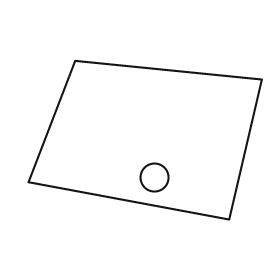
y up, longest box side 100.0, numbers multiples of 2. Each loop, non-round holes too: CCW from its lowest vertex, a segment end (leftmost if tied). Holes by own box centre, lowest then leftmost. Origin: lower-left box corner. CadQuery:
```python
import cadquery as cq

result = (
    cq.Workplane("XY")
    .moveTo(86.0, 0.0)
    .lineTo(100.0, 60.0)
    .lineTo(20.0, 68.0)
    .lineTo(0.0, 16.0)
    .close()
    .moveTo(54.0, 18.0)
    .circle(6.0)
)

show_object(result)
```